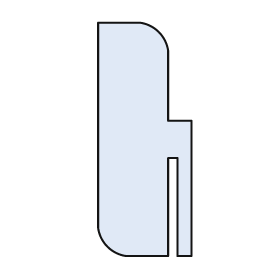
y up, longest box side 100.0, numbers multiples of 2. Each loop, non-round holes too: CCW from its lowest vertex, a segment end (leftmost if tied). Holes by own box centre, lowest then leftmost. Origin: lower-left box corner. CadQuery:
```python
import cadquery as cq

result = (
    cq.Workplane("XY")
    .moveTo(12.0, 0.0)
    .lineTo(30.0, 0.0)
    .lineTo(30.0, 42.0)
    .lineTo(34.0, 42.0)
    .lineTo(34.0, 0.0)
    .lineTo(40.0, 0.0)
    .lineTo(40.0, 58.0)
    .lineTo(30.0, 58.0)
    .lineTo(30.0, 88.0)
    .threePointArc((26.0, 96.0), (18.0, 100.0))
    .lineTo(0.0, 100.0)
    .lineTo(0.0, 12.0)
    .threePointArc((4.0, 4.0), (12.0, 0.0))
    .close()
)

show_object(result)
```